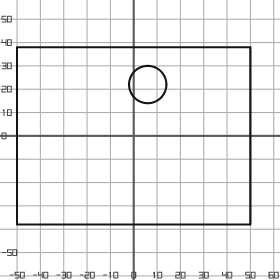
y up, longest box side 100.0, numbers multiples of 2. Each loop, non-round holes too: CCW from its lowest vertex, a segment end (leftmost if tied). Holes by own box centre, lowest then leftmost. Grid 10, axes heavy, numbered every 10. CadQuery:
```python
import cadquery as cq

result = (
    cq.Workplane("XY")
    .moveTo(-50.0, -38.0)
    .lineTo(50.0, -38.0)
    .lineTo(50.0, 38.0)
    .lineTo(-50.0, 38.0)
    .close()
    .moveTo(6.0, 22.0)
    .circle(8.0)
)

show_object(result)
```